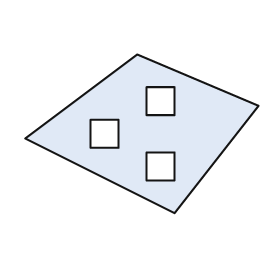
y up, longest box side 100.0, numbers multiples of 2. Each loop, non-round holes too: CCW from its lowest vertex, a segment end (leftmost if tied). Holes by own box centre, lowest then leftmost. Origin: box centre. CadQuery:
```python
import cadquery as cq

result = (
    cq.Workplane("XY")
    .moveTo(14.0, -34.0)
    .lineTo(50.0, 12.0)
    .lineTo(-2.0, 34.0)
    .lineTo(-50.0, -2.0)
    .close()
    .moveTo(2.0, -20.0)
    .lineTo(14.0, -20.0)
    .lineTo(14.0, -8.0)
    .lineTo(2.0, -8.0)
    .close()
    .moveTo(-22.0, -6.0)
    .lineTo(-10.0, -6.0)
    .lineTo(-10.0, 6.0)
    .lineTo(-22.0, 6.0)
    .close()
    .moveTo(2.0, 8.0)
    .lineTo(14.0, 8.0)
    .lineTo(14.0, 20.0)
    .lineTo(2.0, 20.0)
    .close()
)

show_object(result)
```